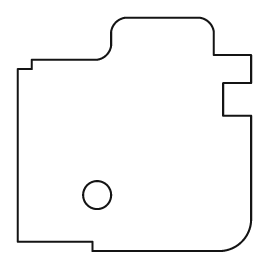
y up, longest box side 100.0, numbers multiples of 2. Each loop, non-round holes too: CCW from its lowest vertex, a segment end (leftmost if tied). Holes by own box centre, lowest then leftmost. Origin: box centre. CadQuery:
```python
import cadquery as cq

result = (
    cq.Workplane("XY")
    .moveTo(-18.0, -50.0)
    .lineTo(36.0, -50.0)
    .threePointArc((46.0, -46.0), (50.0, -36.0))
    .lineTo(50.0, 8.0)
    .lineTo(38.0, 8.0)
    .lineTo(38.0, 22.0)
    .lineTo(50.0, 22.0)
    .lineTo(50.0, 34.0)
    .lineTo(34.0, 34.0)
    .lineTo(34.0, 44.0)
    .threePointArc((32.0, 48.0), (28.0, 50.0))
    .lineTo(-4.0, 50.0)
    .threePointArc((-8.0, 48.0), (-10.0, 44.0))
    .lineTo(-10.0, 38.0)
    .threePointArc((-12.0, 34.0), (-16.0, 32.0))
    .lineTo(-44.0, 32.0)
    .lineTo(-44.0, 28.0)
    .lineTo(-50.0, 28.0)
    .lineTo(-50.0, -46.0)
    .lineTo(-18.0, -46.0)
    .close()
    .moveTo(-16.0, -26.0)
    .circle(6.0)
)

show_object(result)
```